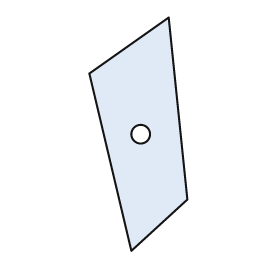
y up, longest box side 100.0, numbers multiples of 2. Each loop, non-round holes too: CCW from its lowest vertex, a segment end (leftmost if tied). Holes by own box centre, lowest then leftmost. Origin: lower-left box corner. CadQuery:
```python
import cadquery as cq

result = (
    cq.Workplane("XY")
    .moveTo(18.0, 0.0)
    .lineTo(42.0, 22.0)
    .lineTo(34.0, 100.0)
    .lineTo(0.0, 76.0)
    .close()
    .moveTo(22.0, 50.0)
    .circle(4.0)
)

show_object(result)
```